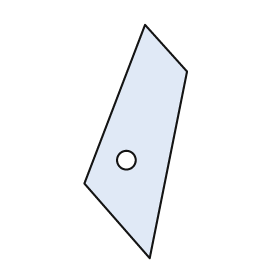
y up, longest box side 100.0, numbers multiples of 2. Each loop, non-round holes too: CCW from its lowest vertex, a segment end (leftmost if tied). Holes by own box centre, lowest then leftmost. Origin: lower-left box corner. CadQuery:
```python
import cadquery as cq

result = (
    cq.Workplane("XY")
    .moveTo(28.0, 0.0)
    .lineTo(44.0, 80.0)
    .lineTo(26.0, 100.0)
    .lineTo(0.0, 32.0)
    .close()
    .moveTo(18.0, 42.0)
    .circle(4.0)
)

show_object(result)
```